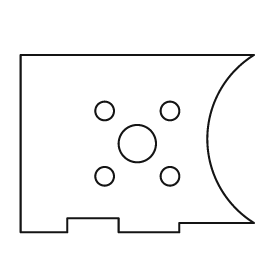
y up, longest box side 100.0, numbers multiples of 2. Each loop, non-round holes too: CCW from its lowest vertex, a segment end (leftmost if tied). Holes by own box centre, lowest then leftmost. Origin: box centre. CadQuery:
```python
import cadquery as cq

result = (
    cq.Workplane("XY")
    .moveTo(-50.0, -38.0)
    .lineTo(-30.0, -38.0)
    .lineTo(-30.0, -32.0)
    .lineTo(-8.0, -32.0)
    .lineTo(-8.0, -38.0)
    .lineTo(18.0, -38.0)
    .lineTo(18.0, -34.0)
    .lineTo(50.0, -34.0)
    .threePointArc((30.0, 2.0), (50.0, 38.0))
    .lineTo(-50.0, 38.0)
    .close()
    .moveTo(-14.0, -14.0)
    .circle(4.0)
    .moveTo(14.0, -14.0)
    .circle(4.0)
    .moveTo(0.0, 0.0)
    .circle(8.0)
    .moveTo(-14.0, 14.0)
    .circle(4.0)
    .moveTo(14.0, 14.0)
    .circle(4.0)
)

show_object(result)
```